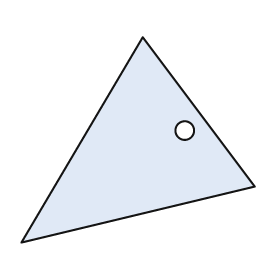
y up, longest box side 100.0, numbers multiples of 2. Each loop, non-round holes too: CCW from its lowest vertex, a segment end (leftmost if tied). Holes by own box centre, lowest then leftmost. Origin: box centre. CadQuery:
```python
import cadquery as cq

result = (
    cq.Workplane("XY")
    .moveTo(-50.0, -44.0)
    .lineTo(50.0, -20.0)
    .lineTo(2.0, 44.0)
    .close()
    .moveTo(20.0, 4.0)
    .circle(4.0)
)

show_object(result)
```